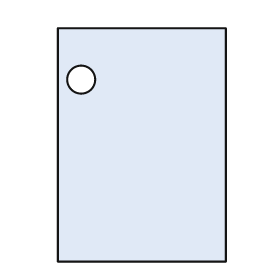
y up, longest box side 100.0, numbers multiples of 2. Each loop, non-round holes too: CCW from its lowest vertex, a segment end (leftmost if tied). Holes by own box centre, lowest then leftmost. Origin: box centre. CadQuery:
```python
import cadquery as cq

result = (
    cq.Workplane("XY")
    .moveTo(-36.0, -50.0)
    .lineTo(36.0, -50.0)
    .lineTo(36.0, 50.0)
    .lineTo(-36.0, 50.0)
    .close()
    .moveTo(-26.0, 28.0)
    .circle(6.0)
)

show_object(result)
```